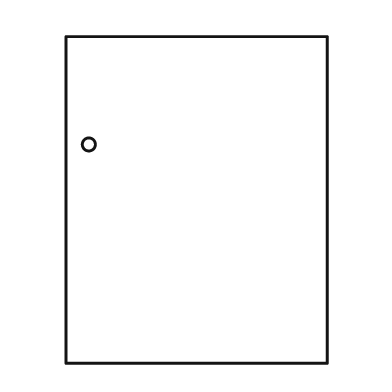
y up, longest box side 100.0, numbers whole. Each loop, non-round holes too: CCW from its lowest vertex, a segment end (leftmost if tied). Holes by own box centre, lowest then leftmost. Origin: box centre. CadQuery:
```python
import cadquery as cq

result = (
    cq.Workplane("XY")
    .moveTo(-40.0, -50.0)
    .lineTo(40.0, -50.0)
    .lineTo(40.0, 50.0)
    .lineTo(-40.0, 50.0)
    .close()
    .moveTo(-33.0, 17.0)
    .circle(2.0)
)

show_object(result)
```